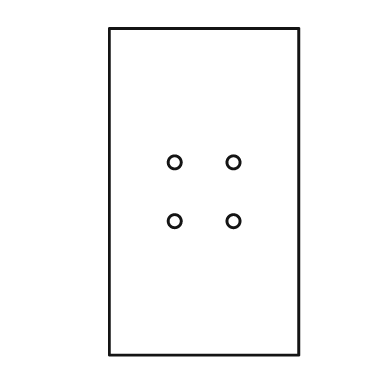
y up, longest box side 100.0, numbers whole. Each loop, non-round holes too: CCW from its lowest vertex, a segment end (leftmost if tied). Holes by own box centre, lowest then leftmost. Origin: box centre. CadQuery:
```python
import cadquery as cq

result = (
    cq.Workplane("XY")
    .moveTo(-29.0, -50.0)
    .lineTo(29.0, -50.0)
    .lineTo(29.0, 50.0)
    .lineTo(-29.0, 50.0)
    .close()
    .moveTo(-9.0, -9.0)
    .circle(2.0)
    .moveTo(9.0, -9.0)
    .circle(2.0)
    .moveTo(-9.0, 9.0)
    .circle(2.0)
    .moveTo(9.0, 9.0)
    .circle(2.0)
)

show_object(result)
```